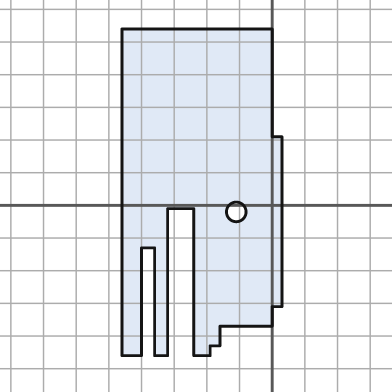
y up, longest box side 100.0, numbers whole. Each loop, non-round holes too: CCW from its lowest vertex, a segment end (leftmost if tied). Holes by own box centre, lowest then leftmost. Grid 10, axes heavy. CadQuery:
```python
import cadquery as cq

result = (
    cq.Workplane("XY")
    .moveTo(-46.0, -46.0)
    .lineTo(-40.0, -46.0)
    .lineTo(-40.0, -13.0)
    .lineTo(-36.0, -13.0)
    .lineTo(-36.0, -46.0)
    .lineTo(-32.0, -46.0)
    .lineTo(-32.0, -1.0)
    .lineTo(-24.0, -1.0)
    .lineTo(-24.0, -46.0)
    .lineTo(-19.0, -46.0)
    .lineTo(-19.0, -43.0)
    .lineTo(-16.0, -43.0)
    .lineTo(-16.0, -37.0)
    .lineTo(0.0, -37.0)
    .lineTo(0.0, -31.0)
    .lineTo(3.0, -31.0)
    .lineTo(3.0, 21.0)
    .lineTo(0.0, 21.0)
    .lineTo(0.0, 54.0)
    .lineTo(-46.0, 54.0)
    .close()
    .moveTo(-11.0, -2.0)
    .circle(3.0)
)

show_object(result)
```